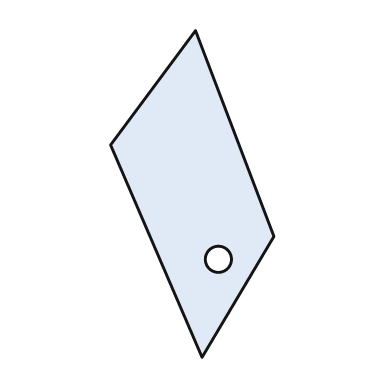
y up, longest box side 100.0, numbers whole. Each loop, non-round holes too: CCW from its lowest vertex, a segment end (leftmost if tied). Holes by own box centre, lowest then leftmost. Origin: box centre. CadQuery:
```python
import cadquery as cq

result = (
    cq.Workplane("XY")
    .moveTo(3.0, -50.0)
    .lineTo(25.0, -13.0)
    .lineTo(1.0, 50.0)
    .lineTo(-25.0, 15.0)
    .close()
    .moveTo(8.0, -20.0)
    .circle(4.0)
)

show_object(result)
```